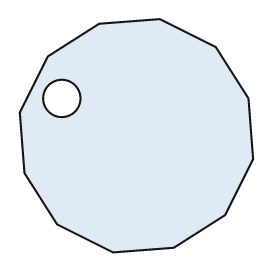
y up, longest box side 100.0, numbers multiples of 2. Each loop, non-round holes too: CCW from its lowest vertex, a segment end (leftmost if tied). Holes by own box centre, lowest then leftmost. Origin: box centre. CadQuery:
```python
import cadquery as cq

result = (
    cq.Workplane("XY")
    .moveTo(-10.0, -50.0)
    .lineTo(16.0, -48.0)
    .lineTo(38.0, -34.0)
    .lineTo(50.0, -10.0)
    .lineTo(48.0, 16.0)
    .lineTo(34.0, 38.0)
    .lineTo(10.0, 50.0)
    .lineTo(-16.0, 48.0)
    .lineTo(-38.0, 34.0)
    .lineTo(-50.0, 10.0)
    .lineTo(-48.0, -16.0)
    .lineTo(-34.0, -38.0)
    .close()
    .moveTo(-32.0, 16.0)
    .circle(8.0)
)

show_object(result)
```